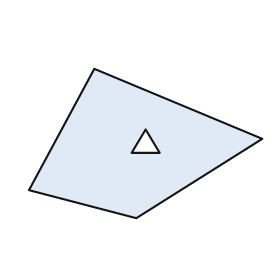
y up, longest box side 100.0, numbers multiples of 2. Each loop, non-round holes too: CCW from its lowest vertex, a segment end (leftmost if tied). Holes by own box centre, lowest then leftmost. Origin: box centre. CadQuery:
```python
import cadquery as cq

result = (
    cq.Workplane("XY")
    .moveTo(-4.0, -32.0)
    .lineTo(50.0, 2.0)
    .lineTo(-22.0, 32.0)
    .lineTo(-50.0, -20.0)
    .close()
    .moveTo(-6.0, -4.0)
    .lineTo(6.0, -4.0)
    .lineTo(0.0, 6.0)
    .close()
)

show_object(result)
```